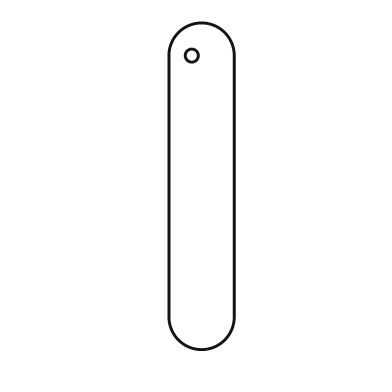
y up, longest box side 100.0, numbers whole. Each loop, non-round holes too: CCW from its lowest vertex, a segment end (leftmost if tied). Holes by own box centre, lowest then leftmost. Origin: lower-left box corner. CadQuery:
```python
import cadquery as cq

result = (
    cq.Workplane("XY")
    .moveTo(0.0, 10.0)
    .threePointArc((10.0, 0.0), (20.0, 10.0))
    .lineTo(20.0, 90.0)
    .threePointArc((10.0, 100.0), (0.0, 90.0))
    .close()
    .moveTo(7.0, 90.0)
    .circle(2.0)
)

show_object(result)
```